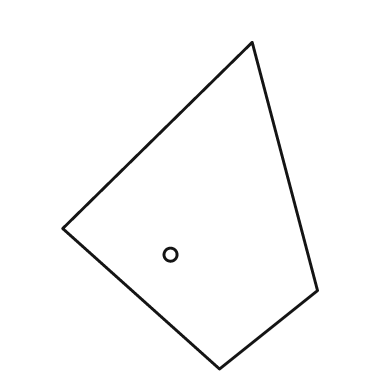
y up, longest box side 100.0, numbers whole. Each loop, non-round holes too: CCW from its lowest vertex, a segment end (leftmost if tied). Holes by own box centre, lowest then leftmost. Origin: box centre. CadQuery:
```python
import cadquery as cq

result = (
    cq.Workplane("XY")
    .moveTo(9.0, -50.0)
    .lineTo(39.0, -26.0)
    .lineTo(19.0, 50.0)
    .lineTo(-39.0, -7.0)
    .close()
    .moveTo(-6.0, -15.0)
    .circle(2.0)
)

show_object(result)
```